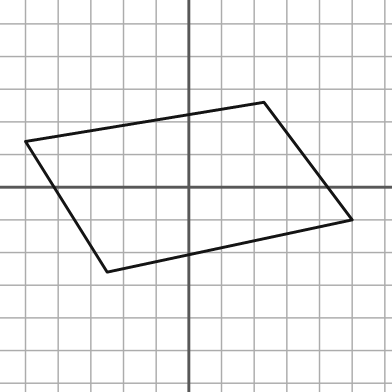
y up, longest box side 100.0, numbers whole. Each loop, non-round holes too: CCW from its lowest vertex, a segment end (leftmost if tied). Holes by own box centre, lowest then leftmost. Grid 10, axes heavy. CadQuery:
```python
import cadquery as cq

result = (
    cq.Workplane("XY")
    .moveTo(-25.0, -26.0)
    .lineTo(50.0, -10.0)
    .lineTo(23.0, 26.0)
    .lineTo(-50.0, 14.0)
    .close()
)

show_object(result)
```